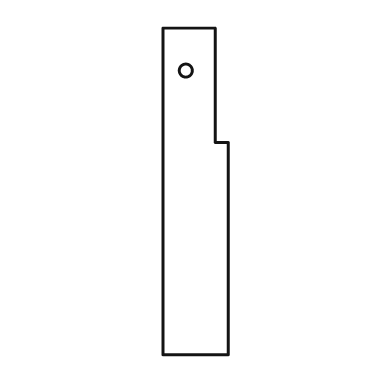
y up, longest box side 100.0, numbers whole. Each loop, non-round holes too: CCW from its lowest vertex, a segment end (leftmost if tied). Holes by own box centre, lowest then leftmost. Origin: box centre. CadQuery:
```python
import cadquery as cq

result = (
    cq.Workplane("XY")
    .moveTo(-10.0, -50.0)
    .lineTo(10.0, -50.0)
    .lineTo(10.0, 15.0)
    .lineTo(6.0, 15.0)
    .lineTo(6.0, 50.0)
    .lineTo(-10.0, 50.0)
    .close()
    .moveTo(-3.0, 37.0)
    .circle(2.0)
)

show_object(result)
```